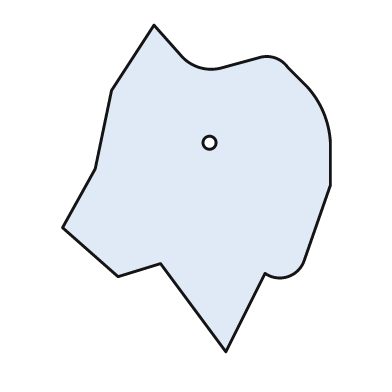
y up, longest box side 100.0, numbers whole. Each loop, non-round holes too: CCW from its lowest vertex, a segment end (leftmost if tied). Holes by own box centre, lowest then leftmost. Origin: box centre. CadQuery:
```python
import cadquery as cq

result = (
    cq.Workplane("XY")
    .moveTo(9.0, -50.0)
    .lineTo(21.0, -26.0)
    .threePointArc((28.0, -27.0), (33.0, -22.0))
    .lineTo(41.0, 1.0)
    .lineTo(41.0, 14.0)
    .threePointArc((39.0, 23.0), (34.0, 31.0))
    .lineTo(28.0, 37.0)
    .threePointArc((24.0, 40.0), (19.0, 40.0))
    .lineTo(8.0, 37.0)
    .threePointArc((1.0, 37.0), (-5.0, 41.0))
    .lineTo(-13.0, 50.0)
    .lineTo(-26.0, 30.0)
    .lineTo(-31.0, 6.0)
    .lineTo(-41.0, -12.0)
    .lineTo(-24.0, -27.0)
    .lineTo(-11.0, -23.0)
    .close()
    .moveTo(4.0, 14.0)
    .circle(2.0)
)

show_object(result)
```